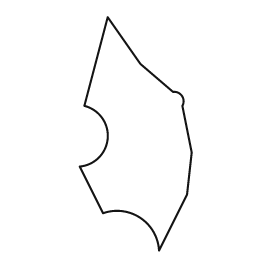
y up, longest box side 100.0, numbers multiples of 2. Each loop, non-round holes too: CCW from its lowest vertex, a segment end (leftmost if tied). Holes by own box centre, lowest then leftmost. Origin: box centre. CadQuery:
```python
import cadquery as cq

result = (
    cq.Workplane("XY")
    .moveTo(10.0, -50.0)
    .lineTo(22.0, -26.0)
    .lineTo(24.0, -8.0)
    .lineTo(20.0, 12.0)
    .threePointArc((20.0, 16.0), (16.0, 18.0))
    .lineTo(2.0, 30.0)
    .lineTo(-12.0, 50.0)
    .lineTo(-22.0, 12.0)
    .threePointArc((-12.0, -2.0), (-24.0, -14.0))
    .lineTo(-14.0, -34.0)
    .threePointArc((2.0, -36.0), (10.0, -50.0))
    .close()
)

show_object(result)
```